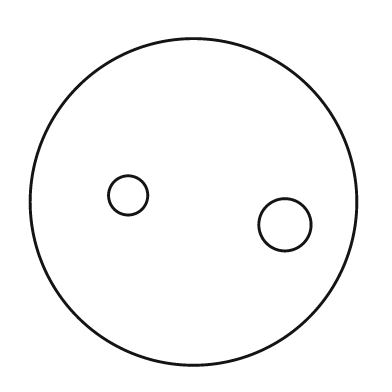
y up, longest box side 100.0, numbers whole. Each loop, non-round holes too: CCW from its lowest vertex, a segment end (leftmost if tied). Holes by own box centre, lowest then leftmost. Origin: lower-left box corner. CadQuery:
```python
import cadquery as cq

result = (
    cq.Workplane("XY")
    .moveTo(50.0, 50.0)
    .circle(50.0)
    .moveTo(78.0, 43.0)
    .circle(8.0)
    .moveTo(30.0, 52.0)
    .circle(6.0)
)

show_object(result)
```